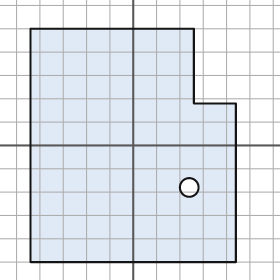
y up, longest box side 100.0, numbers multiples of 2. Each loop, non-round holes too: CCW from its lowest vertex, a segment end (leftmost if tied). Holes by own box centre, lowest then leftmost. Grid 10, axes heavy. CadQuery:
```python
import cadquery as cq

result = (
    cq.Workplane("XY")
    .moveTo(-44.0, -50.0)
    .lineTo(44.0, -50.0)
    .lineTo(44.0, 18.0)
    .lineTo(26.0, 18.0)
    .lineTo(26.0, 50.0)
    .lineTo(-44.0, 50.0)
    .close()
    .moveTo(24.0, -18.0)
    .circle(4.0)
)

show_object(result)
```